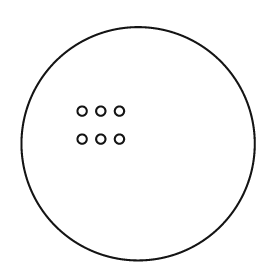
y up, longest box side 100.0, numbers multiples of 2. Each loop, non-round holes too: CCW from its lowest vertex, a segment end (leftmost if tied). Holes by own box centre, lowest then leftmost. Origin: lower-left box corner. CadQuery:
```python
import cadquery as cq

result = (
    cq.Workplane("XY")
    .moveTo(50.0, 50.0)
    .circle(50.0)
    .moveTo(26.0, 52.0)
    .circle(2.0)
    .moveTo(34.0, 52.0)
    .circle(2.0)
    .moveTo(42.0, 52.0)
    .circle(2.0)
    .moveTo(26.0, 64.0)
    .circle(2.0)
    .moveTo(34.0, 64.0)
    .circle(2.0)
    .moveTo(42.0, 64.0)
    .circle(2.0)
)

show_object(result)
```